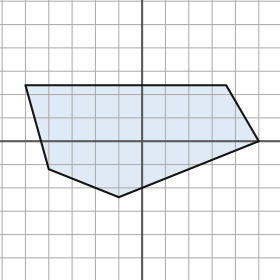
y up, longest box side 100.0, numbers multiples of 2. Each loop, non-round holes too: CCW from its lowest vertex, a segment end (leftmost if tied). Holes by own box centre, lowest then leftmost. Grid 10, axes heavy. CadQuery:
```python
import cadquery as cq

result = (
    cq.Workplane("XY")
    .moveTo(-10.0, -24.0)
    .lineTo(50.0, 0.0)
    .lineTo(36.0, 24.0)
    .lineTo(-50.0, 24.0)
    .lineTo(-40.0, -12.0)
    .close()
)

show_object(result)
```